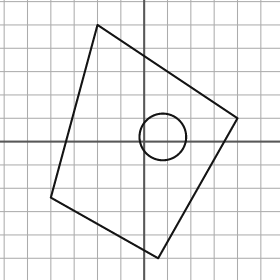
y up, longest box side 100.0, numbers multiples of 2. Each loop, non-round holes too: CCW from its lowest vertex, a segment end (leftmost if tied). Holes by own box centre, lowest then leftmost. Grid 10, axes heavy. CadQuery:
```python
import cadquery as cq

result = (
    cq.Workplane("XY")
    .moveTo(6.0, -50.0)
    .lineTo(40.0, 10.0)
    .lineTo(-20.0, 50.0)
    .lineTo(-40.0, -24.0)
    .close()
    .moveTo(8.0, 2.0)
    .circle(10.0)
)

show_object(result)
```